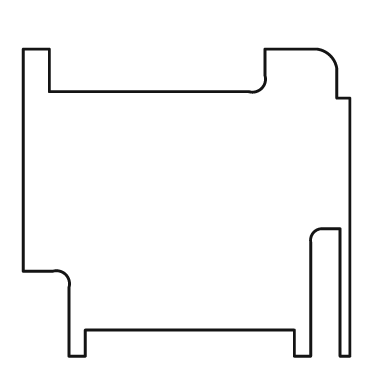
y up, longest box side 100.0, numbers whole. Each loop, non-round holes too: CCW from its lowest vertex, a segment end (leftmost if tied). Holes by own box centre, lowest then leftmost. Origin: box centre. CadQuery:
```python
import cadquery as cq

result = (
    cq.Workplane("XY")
    .moveTo(-36.0, -47.0)
    .lineTo(-31.0, -47.0)
    .lineTo(-31.0, -39.0)
    .lineTo(33.0, -39.0)
    .lineTo(33.0, -47.0)
    .lineTo(38.0, -47.0)
    .lineTo(38.0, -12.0)
    .threePointArc((39.0, -9.0), (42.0, -8.0))
    .lineTo(47.0, -8.0)
    .lineTo(47.0, -47.0)
    .lineTo(50.0, -47.0)
    .lineTo(50.0, 32.0)
    .lineTo(46.0, 32.0)
    .lineTo(46.0, 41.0)
    .threePointArc((44.0, 45.0), (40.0, 47.0))
    .lineTo(24.0, 47.0)
    .lineTo(24.0, 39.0)
    .threePointArc((23.0, 35.0), (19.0, 34.0))
    .lineTo(-42.0, 34.0)
    .lineTo(-42.0, 47.0)
    .lineTo(-50.0, 47.0)
    .lineTo(-50.0, -21.0)
    .lineTo(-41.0, -21.0)
    .threePointArc((-37.0, -22.0), (-36.0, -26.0))
    .close()
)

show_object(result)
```